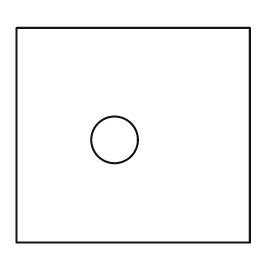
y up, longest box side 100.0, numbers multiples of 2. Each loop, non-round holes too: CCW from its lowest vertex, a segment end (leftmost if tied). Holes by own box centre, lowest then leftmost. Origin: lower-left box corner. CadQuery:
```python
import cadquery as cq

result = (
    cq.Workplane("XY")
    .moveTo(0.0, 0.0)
    .lineTo(100.0, 0.0)
    .lineTo(100.0, 92.0)
    .lineTo(0.0, 92.0)
    .close()
    .moveTo(42.0, 44.0)
    .circle(10.0)
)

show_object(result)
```